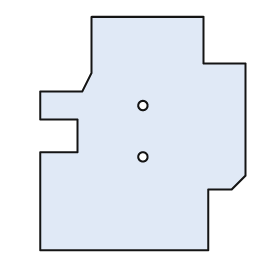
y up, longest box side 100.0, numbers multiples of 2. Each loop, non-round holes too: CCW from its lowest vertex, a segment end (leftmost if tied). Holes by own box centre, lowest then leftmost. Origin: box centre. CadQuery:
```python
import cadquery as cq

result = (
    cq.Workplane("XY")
    .moveTo(-44.0, -50.0)
    .lineTo(28.0, -50.0)
    .lineTo(28.0, -24.0)
    .lineTo(38.0, -24.0)
    .lineTo(44.0, -18.0)
    .lineTo(44.0, 30.0)
    .lineTo(26.0, 30.0)
    .lineTo(26.0, 50.0)
    .lineTo(-22.0, 50.0)
    .lineTo(-22.0, 26.0)
    .lineTo(-26.0, 18.0)
    .lineTo(-44.0, 18.0)
    .lineTo(-44.0, 6.0)
    .lineTo(-28.0, 6.0)
    .lineTo(-28.0, -8.0)
    .lineTo(-44.0, -8.0)
    .close()
    .moveTo(0.0, -10.0)
    .circle(2.0)
    .moveTo(0.0, 12.0)
    .circle(2.0)
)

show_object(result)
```